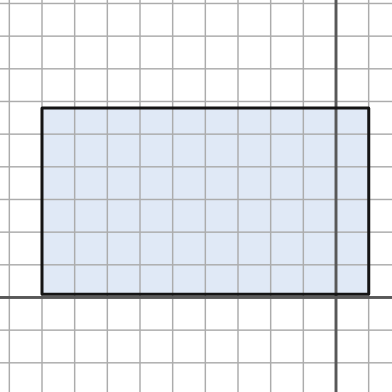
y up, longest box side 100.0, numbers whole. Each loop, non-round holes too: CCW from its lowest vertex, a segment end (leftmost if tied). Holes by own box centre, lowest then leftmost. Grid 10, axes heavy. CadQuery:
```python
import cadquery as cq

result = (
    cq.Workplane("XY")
    .moveTo(-90.0, 1.0)
    .lineTo(10.0, 1.0)
    .lineTo(10.0, 58.0)
    .lineTo(-90.0, 58.0)
    .close()
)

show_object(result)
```